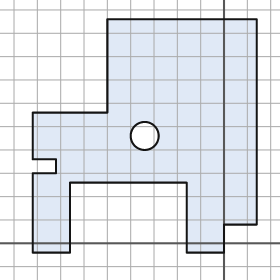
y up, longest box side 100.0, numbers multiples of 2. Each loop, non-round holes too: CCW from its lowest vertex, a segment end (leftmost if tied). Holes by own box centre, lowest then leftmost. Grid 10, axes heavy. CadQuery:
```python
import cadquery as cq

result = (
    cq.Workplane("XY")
    .moveTo(-82.0, -4.0)
    .lineTo(-66.0, -4.0)
    .lineTo(-66.0, 26.0)
    .lineTo(-16.0, 26.0)
    .lineTo(-16.0, -4.0)
    .lineTo(0.0, -4.0)
    .lineTo(0.0, 8.0)
    .lineTo(14.0, 8.0)
    .lineTo(14.0, 96.0)
    .lineTo(-50.0, 96.0)
    .lineTo(-50.0, 56.0)
    .lineTo(-82.0, 56.0)
    .lineTo(-82.0, 36.0)
    .lineTo(-72.0, 36.0)
    .lineTo(-72.0, 30.0)
    .lineTo(-82.0, 30.0)
    .close()
    .moveTo(-34.0, 46.0)
    .circle(6.0)
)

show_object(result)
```